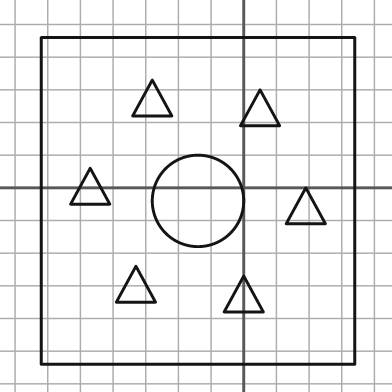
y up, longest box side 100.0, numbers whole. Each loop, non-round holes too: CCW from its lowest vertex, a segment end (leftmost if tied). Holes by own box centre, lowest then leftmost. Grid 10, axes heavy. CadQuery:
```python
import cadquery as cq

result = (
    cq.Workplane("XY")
    .moveTo(-62.0, -54.0)
    .lineTo(34.0, -54.0)
    .lineTo(34.0, 46.0)
    .lineTo(-62.0, 46.0)
    .close()
    .moveTo(-6.0, -38.0)
    .lineTo(6.0, -38.0)
    .lineTo(0.0, -27.0)
    .close()
    .moveTo(-39.0, -35.0)
    .lineTo(-27.0, -35.0)
    .lineTo(-33.0, -24.0)
    .close()
    .moveTo(13.0, -11.0)
    .lineTo(25.0, -11.0)
    .lineTo(19.0, 0.0)
    .close()
    .moveTo(-14.0, -4.0)
    .circle(14.0)
    .moveTo(-53.0, -5.0)
    .lineTo(-41.0, -5.0)
    .lineTo(-47.0, 6.0)
    .close()
    .moveTo(-1.0, 19.0)
    .lineTo(11.0, 19.0)
    .lineTo(5.0, 30.0)
    .close()
    .moveTo(-34.0, 22.0)
    .lineTo(-22.0, 22.0)
    .lineTo(-28.0, 33.0)
    .close()
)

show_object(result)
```